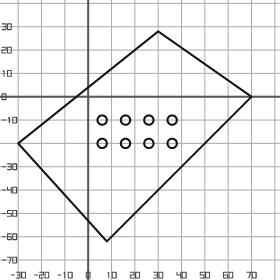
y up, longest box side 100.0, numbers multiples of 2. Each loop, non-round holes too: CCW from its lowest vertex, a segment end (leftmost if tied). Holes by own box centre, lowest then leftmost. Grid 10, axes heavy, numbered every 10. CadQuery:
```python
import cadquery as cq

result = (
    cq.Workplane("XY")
    .moveTo(8.0, -62.0)
    .lineTo(70.0, 0.0)
    .lineTo(30.0, 28.0)
    .lineTo(-30.0, -20.0)
    .close()
    .moveTo(6.0, -20.0)
    .circle(2.0)
    .moveTo(16.0, -20.0)
    .circle(2.0)
    .moveTo(26.0, -20.0)
    .circle(2.0)
    .moveTo(36.0, -20.0)
    .circle(2.0)
    .moveTo(6.0, -10.0)
    .circle(2.0)
    .moveTo(16.0, -10.0)
    .circle(2.0)
    .moveTo(26.0, -10.0)
    .circle(2.0)
    .moveTo(36.0, -10.0)
    .circle(2.0)
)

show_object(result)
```